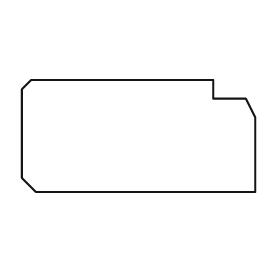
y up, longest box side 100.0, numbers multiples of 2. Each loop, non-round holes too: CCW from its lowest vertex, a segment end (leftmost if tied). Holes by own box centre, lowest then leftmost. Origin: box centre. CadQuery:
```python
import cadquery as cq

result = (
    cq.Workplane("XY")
    .moveTo(-44.0, -24.0)
    .lineTo(50.0, -24.0)
    .lineTo(50.0, 8.0)
    .lineTo(46.0, 16.0)
    .lineTo(32.0, 16.0)
    .lineTo(32.0, 24.0)
    .lineTo(-46.0, 24.0)
    .lineTo(-50.0, 20.0)
    .lineTo(-50.0, -18.0)
    .close()
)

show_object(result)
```